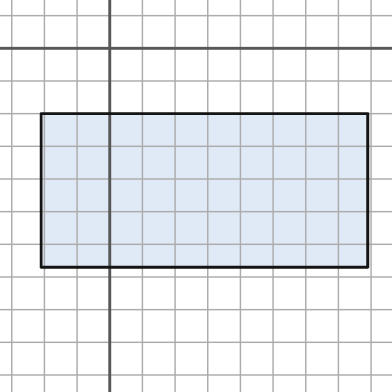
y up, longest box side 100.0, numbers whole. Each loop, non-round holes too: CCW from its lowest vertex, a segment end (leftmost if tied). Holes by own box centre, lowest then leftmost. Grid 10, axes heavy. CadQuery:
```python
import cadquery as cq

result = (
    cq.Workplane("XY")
    .moveTo(-21.0, -67.0)
    .lineTo(79.0, -67.0)
    .lineTo(79.0, -20.0)
    .lineTo(-21.0, -20.0)
    .close()
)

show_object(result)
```